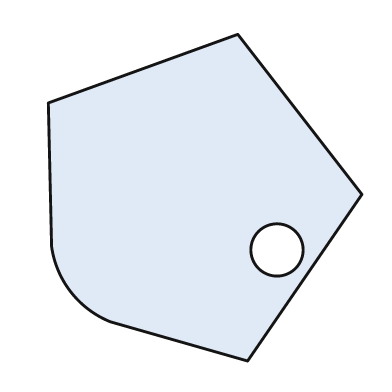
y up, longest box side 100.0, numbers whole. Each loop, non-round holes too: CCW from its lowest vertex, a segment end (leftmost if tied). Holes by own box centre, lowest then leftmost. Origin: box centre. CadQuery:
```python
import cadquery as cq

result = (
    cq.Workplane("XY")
    .moveTo(13.0, -50.0)
    .lineTo(48.0, 1.0)
    .lineTo(10.0, 50.0)
    .lineTo(-48.0, 29.0)
    .lineTo(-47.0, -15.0)
    .threePointArc((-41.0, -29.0), (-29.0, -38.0))
    .close()
    .moveTo(22.0, -16.0)
    .circle(8.0)
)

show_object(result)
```